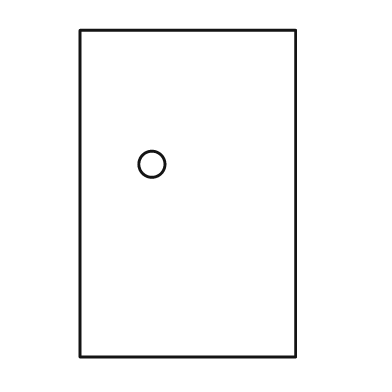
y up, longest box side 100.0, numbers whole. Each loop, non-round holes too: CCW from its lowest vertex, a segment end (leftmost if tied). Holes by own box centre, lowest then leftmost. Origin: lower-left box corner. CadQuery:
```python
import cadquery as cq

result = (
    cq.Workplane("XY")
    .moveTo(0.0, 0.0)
    .lineTo(66.0, 0.0)
    .lineTo(66.0, 100.0)
    .lineTo(0.0, 100.0)
    .close()
    .moveTo(22.0, 59.0)
    .circle(4.0)
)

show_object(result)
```